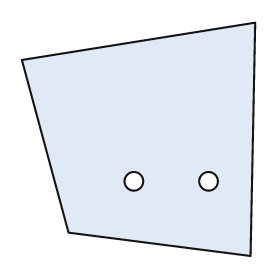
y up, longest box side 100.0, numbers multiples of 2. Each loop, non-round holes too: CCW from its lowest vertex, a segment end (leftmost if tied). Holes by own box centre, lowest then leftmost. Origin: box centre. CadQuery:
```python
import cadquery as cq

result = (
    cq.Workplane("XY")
    .moveTo(48.0, -50.0)
    .lineTo(50.0, 50.0)
    .lineTo(-50.0, 34.0)
    .lineTo(-30.0, -40.0)
    .close()
    .moveTo(-2.0, -18.0)
    .circle(4.0)
    .moveTo(30.0, -18.0)
    .circle(4.0)
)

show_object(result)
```